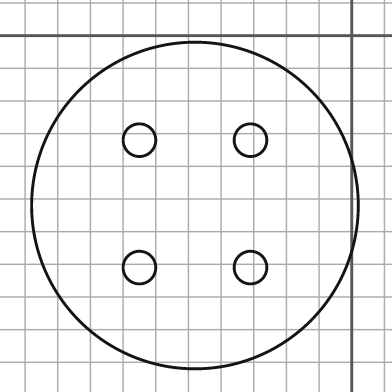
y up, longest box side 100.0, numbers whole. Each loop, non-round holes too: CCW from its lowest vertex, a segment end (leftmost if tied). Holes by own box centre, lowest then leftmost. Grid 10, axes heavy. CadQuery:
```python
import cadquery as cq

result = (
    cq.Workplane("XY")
    .moveTo(-48.0, -52.0)
    .circle(50.0)
    .moveTo(-65.0, -71.0)
    .circle(5.0)
    .moveTo(-31.0, -71.0)
    .circle(5.0)
    .moveTo(-65.0, -32.0)
    .circle(5.0)
    .moveTo(-31.0, -32.0)
    .circle(5.0)
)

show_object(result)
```